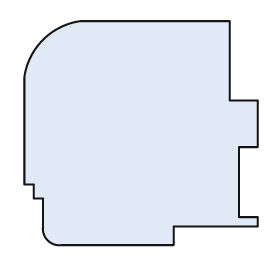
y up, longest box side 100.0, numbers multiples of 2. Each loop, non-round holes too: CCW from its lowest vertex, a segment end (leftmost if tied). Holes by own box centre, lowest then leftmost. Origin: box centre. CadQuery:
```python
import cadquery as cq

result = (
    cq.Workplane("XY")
    .moveTo(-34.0, -48.0)
    .lineTo(14.0, -48.0)
    .lineTo(14.0, -40.0)
    .lineTo(50.0, -40.0)
    .lineTo(50.0, -36.0)
    .lineTo(42.0, -36.0)
    .lineTo(42.0, -6.0)
    .lineTo(50.0, -6.0)
    .lineTo(50.0, 14.0)
    .lineTo(38.0, 14.0)
    .lineTo(38.0, 48.0)
    .lineTo(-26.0, 48.0)
    .threePointArc((-42.0, 40.0), (-50.0, 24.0))
    .lineTo(-50.0, -22.0)
    .lineTo(-46.0, -22.0)
    .lineTo(-46.0, -28.0)
    .lineTo(-42.0, -28.0)
    .lineTo(-42.0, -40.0)
    .threePointArc((-40.0, -46.0), (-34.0, -48.0))
    .close()
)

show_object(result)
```